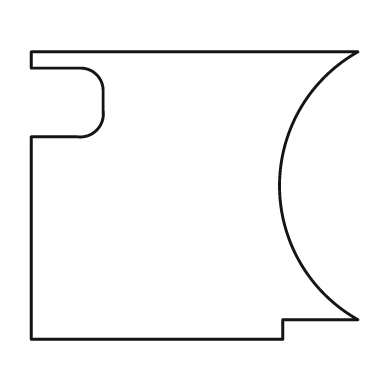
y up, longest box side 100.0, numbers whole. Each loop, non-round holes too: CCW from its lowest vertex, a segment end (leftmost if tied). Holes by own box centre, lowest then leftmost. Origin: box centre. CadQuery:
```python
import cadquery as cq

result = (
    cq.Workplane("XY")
    .moveTo(-50.0, -44.0)
    .lineTo(27.0, -44.0)
    .lineTo(27.0, -38.0)
    .lineTo(50.0, -38.0)
    .threePointArc((26.0, 3.0), (50.0, 44.0))
    .lineTo(-50.0, 44.0)
    .lineTo(-50.0, 39.0)
    .lineTo(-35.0, 39.0)
    .threePointArc((-30.0, 37.0), (-28.0, 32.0))
    .lineTo(-28.0, 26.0)
    .threePointArc((-30.0, 20.0), (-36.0, 18.0))
    .lineTo(-50.0, 18.0)
    .close()
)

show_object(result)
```